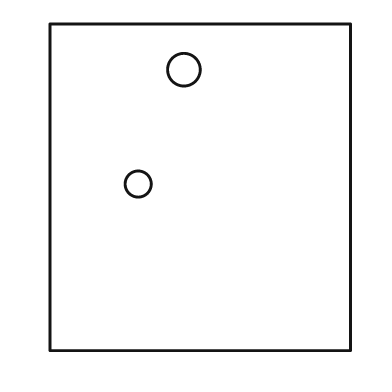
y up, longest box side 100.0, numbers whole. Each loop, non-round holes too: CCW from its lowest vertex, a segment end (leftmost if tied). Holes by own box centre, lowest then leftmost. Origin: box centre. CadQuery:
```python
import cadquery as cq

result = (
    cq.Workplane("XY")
    .moveTo(-46.0, -50.0)
    .lineTo(46.0, -50.0)
    .lineTo(46.0, 50.0)
    .lineTo(-46.0, 50.0)
    .close()
    .moveTo(-19.0, 1.0)
    .circle(4.0)
    .moveTo(-5.0, 36.0)
    .circle(5.0)
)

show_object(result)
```